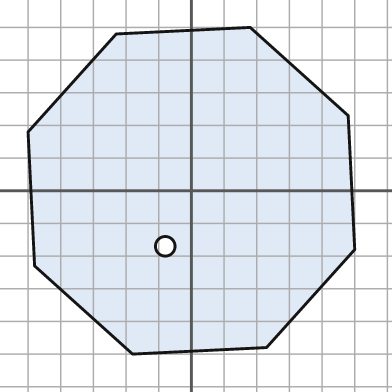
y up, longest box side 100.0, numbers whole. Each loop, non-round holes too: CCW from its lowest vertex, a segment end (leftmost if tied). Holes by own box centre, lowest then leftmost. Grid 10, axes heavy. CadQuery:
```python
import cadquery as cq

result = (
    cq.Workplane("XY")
    .moveTo(-18.0, -50.0)
    .lineTo(23.0, -48.0)
    .lineTo(50.0, -18.0)
    .lineTo(48.0, 23.0)
    .lineTo(18.0, 50.0)
    .lineTo(-23.0, 48.0)
    .lineTo(-50.0, 18.0)
    .lineTo(-48.0, -23.0)
    .close()
    .moveTo(-8.0, -17.0)
    .circle(3.0)
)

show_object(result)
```